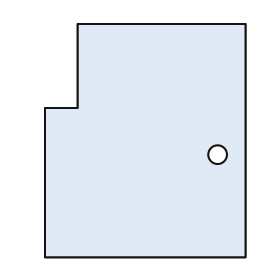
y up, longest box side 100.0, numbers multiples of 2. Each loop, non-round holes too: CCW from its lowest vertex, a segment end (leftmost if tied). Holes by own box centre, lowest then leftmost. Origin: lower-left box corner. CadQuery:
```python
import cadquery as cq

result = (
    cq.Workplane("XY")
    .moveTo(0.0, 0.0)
    .lineTo(86.0, 0.0)
    .lineTo(86.0, 100.0)
    .lineTo(14.0, 100.0)
    .lineTo(14.0, 64.0)
    .lineTo(0.0, 64.0)
    .close()
    .moveTo(74.0, 44.0)
    .circle(4.0)
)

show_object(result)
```